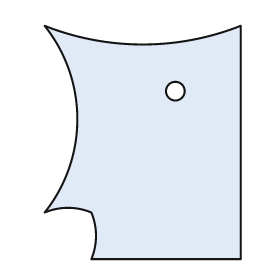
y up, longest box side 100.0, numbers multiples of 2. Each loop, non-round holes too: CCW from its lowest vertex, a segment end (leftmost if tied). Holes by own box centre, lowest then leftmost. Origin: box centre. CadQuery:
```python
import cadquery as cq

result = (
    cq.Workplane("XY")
    .moveTo(-22.0, -50.0)
    .lineTo(42.0, -50.0)
    .lineTo(42.0, 50.0)
    .threePointArc((0.0, 42.0), (-42.0, 50.0))
    .threePointArc((-28.0, 10.0), (-42.0, -30.0))
    .threePointArc((-32.0, -28.0), (-22.0, -30.0))
    .threePointArc((-20.0, -40.0), (-22.0, -50.0))
    .close()
    .moveTo(14.0, 22.0)
    .circle(4.0)
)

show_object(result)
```